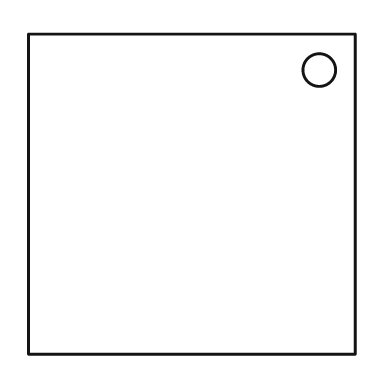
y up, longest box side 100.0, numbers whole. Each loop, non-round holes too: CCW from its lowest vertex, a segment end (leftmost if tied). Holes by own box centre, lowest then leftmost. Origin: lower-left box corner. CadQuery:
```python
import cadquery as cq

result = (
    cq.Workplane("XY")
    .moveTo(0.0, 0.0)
    .lineTo(100.0, 0.0)
    .lineTo(100.0, 98.0)
    .lineTo(0.0, 98.0)
    .close()
    .moveTo(89.0, 87.0)
    .circle(5.0)
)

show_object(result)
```